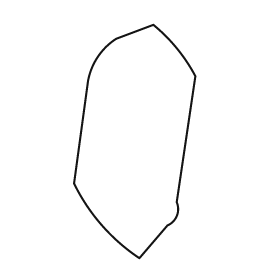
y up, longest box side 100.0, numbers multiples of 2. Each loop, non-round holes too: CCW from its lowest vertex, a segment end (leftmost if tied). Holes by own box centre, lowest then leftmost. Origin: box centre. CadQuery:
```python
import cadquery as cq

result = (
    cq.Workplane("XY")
    .moveTo(2.0, -50.0)
    .lineTo(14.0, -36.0)
    .threePointArc((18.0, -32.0), (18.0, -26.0))
    .lineTo(26.0, 28.0)
    .threePointArc((18.0, 40.0), (8.0, 50.0))
    .lineTo(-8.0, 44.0)
    .threePointArc((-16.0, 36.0), (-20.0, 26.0))
    .lineTo(-26.0, -18.0)
    .threePointArc((-14.0, -36.0), (2.0, -50.0))
    .close()
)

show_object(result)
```